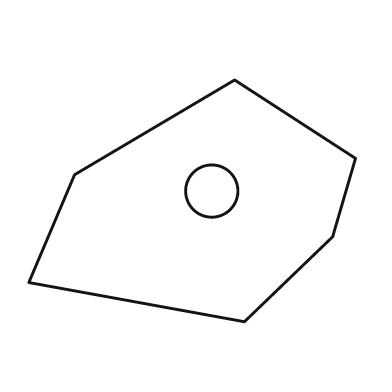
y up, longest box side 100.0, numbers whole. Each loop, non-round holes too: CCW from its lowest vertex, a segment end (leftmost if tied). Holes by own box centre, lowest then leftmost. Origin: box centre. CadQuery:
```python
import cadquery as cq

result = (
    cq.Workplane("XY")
    .moveTo(16.0, -37.0)
    .lineTo(43.0, -11.0)
    .lineTo(50.0, 13.0)
    .lineTo(13.0, 37.0)
    .lineTo(-36.0, 8.0)
    .lineTo(-50.0, -25.0)
    .close()
    .moveTo(6.0, 3.0)
    .circle(8.0)
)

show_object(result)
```